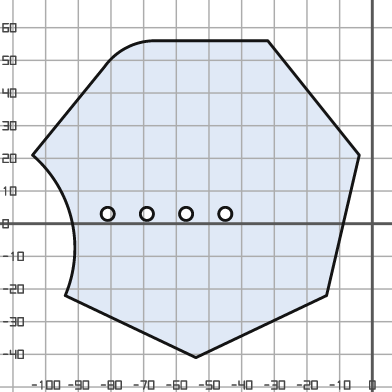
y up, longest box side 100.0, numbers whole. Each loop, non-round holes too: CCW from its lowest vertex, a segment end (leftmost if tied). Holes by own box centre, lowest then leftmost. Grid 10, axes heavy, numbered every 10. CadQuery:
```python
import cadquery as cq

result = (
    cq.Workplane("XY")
    .moveTo(-54.0, -41.0)
    .lineTo(-14.0, -22.0)
    .lineTo(-4.0, 21.0)
    .lineTo(-32.0, 56.0)
    .lineTo(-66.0, 56.0)
    .threePointArc((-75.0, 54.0), (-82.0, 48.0))
    .lineTo(-104.0, 21.0)
    .threePointArc((-92.0, 1.0), (-94.0, -22.0))
    .close()
    .moveTo(-81.0, 3.0)
    .circle(2.0)
    .moveTo(-69.0, 3.0)
    .circle(2.0)
    .moveTo(-57.0, 3.0)
    .circle(2.0)
    .moveTo(-45.0, 3.0)
    .circle(2.0)
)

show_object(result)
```